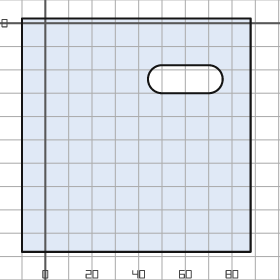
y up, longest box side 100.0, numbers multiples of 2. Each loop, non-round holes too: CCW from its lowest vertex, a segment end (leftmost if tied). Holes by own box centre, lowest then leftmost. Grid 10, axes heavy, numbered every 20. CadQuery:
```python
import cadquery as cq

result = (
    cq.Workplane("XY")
    .moveTo(-10.0, -98.0)
    .lineTo(88.0, -98.0)
    .lineTo(88.0, 2.0)
    .lineTo(-10.0, 2.0)
    .close()
    .moveTo(50.0, -30.0)
    .lineTo(70.0, -30.0)
    .threePointArc((76.0, -24.0), (70.0, -18.0))
    .lineTo(50.0, -18.0)
    .threePointArc((44.0, -24.0), (50.0, -30.0))
    .close()
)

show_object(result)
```